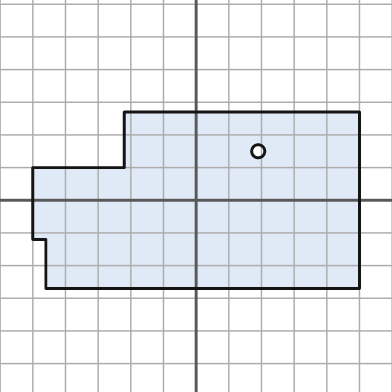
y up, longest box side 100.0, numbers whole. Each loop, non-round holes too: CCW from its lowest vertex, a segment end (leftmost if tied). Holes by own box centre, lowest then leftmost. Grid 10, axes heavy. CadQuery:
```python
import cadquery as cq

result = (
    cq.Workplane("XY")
    .moveTo(-46.0, -27.0)
    .lineTo(50.0, -27.0)
    .lineTo(50.0, 27.0)
    .lineTo(-22.0, 27.0)
    .lineTo(-22.0, 10.0)
    .lineTo(-50.0, 10.0)
    .lineTo(-50.0, -12.0)
    .lineTo(-46.0, -12.0)
    .close()
    .moveTo(19.0, 15.0)
    .circle(2.0)
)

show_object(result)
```